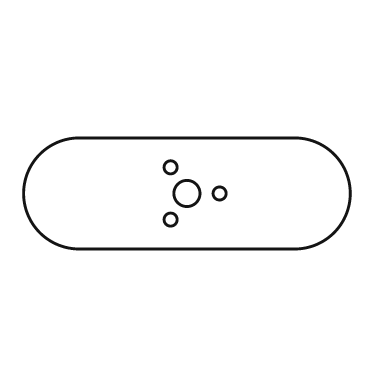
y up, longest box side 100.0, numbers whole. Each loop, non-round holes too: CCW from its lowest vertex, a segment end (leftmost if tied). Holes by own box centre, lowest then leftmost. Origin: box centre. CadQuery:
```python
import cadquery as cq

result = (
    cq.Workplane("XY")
    .moveTo(-33.0, -17.0)
    .lineTo(33.0, -17.0)
    .threePointArc((50.0, 0.0), (33.0, 17.0))
    .lineTo(-33.0, 17.0)
    .threePointArc((-50.0, 0.0), (-33.0, -17.0))
    .close()
    .moveTo(-5.0, -8.0)
    .circle(2.0)
    .moveTo(0.0, 0.0)
    .circle(4.0)
    .moveTo(10.0, 0.0)
    .circle(2.0)
    .moveTo(-5.0, 8.0)
    .circle(2.0)
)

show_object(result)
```